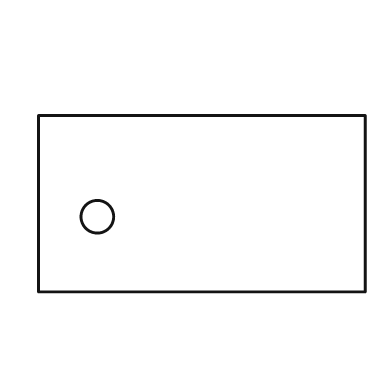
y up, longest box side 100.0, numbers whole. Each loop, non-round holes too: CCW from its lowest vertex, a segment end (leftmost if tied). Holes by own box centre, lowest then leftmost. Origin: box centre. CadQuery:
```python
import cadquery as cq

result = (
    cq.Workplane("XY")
    .moveTo(-50.0, -27.0)
    .lineTo(50.0, -27.0)
    .lineTo(50.0, 27.0)
    .lineTo(-50.0, 27.0)
    .close()
    .moveTo(-32.0, -4.0)
    .circle(5.0)
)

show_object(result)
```